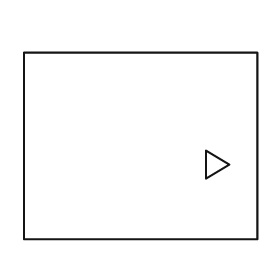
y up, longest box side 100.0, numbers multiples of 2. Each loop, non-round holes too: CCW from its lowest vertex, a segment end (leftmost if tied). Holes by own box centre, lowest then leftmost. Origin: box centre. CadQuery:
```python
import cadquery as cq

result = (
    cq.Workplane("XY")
    .moveTo(-50.0, -40.0)
    .lineTo(50.0, -40.0)
    .lineTo(50.0, 40.0)
    .lineTo(-50.0, 40.0)
    .close()
    .moveTo(28.0, -14.0)
    .lineTo(38.0, -8.0)
    .lineTo(28.0, -2.0)
    .close()
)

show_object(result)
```